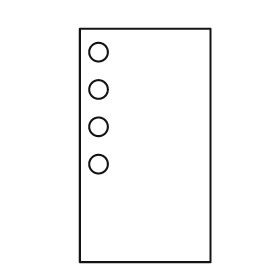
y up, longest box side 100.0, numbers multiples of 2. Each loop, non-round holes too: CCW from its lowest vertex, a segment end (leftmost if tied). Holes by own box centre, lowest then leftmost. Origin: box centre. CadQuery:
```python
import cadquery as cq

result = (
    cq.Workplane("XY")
    .moveTo(-28.0, -50.0)
    .lineTo(28.0, -50.0)
    .lineTo(28.0, 50.0)
    .lineTo(-28.0, 50.0)
    .close()
    .moveTo(-20.0, -8.0)
    .circle(4.0)
    .moveTo(-20.0, 8.0)
    .circle(4.0)
    .moveTo(-20.0, 24.0)
    .circle(4.0)
    .moveTo(-20.0, 40.0)
    .circle(4.0)
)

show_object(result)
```